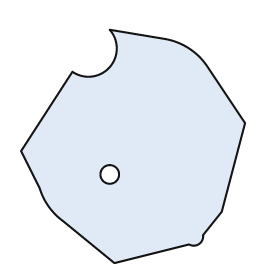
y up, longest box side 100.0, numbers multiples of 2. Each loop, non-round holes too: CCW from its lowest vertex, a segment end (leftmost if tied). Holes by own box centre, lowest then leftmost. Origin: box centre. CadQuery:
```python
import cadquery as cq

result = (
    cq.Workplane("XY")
    .moveTo(-8.0, -50.0)
    .lineTo(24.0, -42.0)
    .threePointArc((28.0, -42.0), (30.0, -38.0))
    .lineTo(38.0, -28.0)
    .lineTo(48.0, 10.0)
    .lineTo(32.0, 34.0)
    .threePointArc((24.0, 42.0), (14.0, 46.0))
    .lineTo(-10.0, 50.0)
    .threePointArc((-10.0, 34.0), (-26.0, 32.0))
    .lineTo(-48.0, -2.0)
    .lineTo(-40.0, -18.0)
    .threePointArc((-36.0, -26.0), (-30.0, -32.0))
    .close()
    .moveTo(-10.0, -12.0)
    .circle(4.0)
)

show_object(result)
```